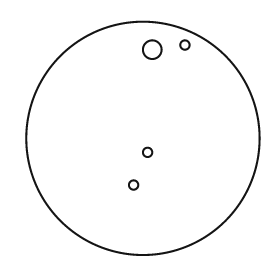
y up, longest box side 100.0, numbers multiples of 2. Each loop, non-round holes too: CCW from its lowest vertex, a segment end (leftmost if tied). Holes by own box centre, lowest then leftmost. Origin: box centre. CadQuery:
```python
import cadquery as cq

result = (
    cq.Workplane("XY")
    .moveTo(0.0, 0.0)
    .circle(50.0)
    .moveTo(-4.0, -20.0)
    .circle(2.0)
    .moveTo(2.0, -6.0)
    .circle(2.0)
    .moveTo(4.0, 38.0)
    .circle(4.0)
    .moveTo(18.0, 40.0)
    .circle(2.0)
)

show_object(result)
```